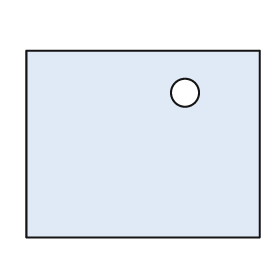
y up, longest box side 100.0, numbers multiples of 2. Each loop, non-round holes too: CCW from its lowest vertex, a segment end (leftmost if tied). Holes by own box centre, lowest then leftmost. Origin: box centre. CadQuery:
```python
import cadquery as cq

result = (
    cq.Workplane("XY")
    .moveTo(-50.0, -40.0)
    .lineTo(50.0, -40.0)
    .lineTo(50.0, 40.0)
    .lineTo(-50.0, 40.0)
    .close()
    .moveTo(18.0, 22.0)
    .circle(6.0)
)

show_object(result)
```